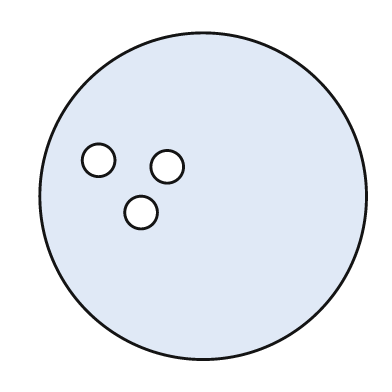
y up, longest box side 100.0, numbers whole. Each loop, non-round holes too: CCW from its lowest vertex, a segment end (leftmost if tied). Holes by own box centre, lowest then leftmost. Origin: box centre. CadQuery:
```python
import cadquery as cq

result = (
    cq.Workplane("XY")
    .moveTo(0.0, 0.0)
    .circle(50.0)
    .moveTo(-19.0, -5.0)
    .circle(5.0)
    .moveTo(-11.0, 9.0)
    .circle(5.0)
    .moveTo(-32.0, 11.0)
    .circle(5.0)
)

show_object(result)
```